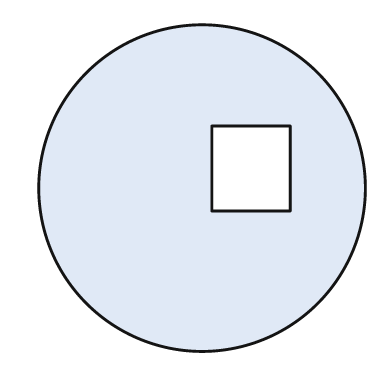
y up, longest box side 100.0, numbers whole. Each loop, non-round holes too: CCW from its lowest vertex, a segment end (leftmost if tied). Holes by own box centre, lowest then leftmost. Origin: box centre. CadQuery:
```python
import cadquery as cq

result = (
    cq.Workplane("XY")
    .moveTo(0.0, 0.0)
    .circle(50.0)
    .moveTo(3.0, -7.0)
    .lineTo(27.0, -7.0)
    .lineTo(27.0, 19.0)
    .lineTo(3.0, 19.0)
    .close()
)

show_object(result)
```